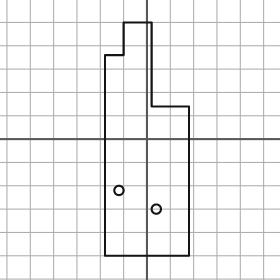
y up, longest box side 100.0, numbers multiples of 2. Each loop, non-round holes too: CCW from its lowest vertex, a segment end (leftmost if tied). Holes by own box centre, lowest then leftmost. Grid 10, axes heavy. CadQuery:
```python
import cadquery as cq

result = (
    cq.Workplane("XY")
    .moveTo(-18.0, -50.0)
    .lineTo(18.0, -50.0)
    .lineTo(18.0, 14.0)
    .lineTo(2.0, 14.0)
    .lineTo(2.0, 50.0)
    .lineTo(-10.0, 50.0)
    .lineTo(-10.0, 36.0)
    .lineTo(-18.0, 36.0)
    .close()
    .moveTo(4.0, -30.0)
    .circle(2.0)
    .moveTo(-12.0, -22.0)
    .circle(2.0)
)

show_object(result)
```